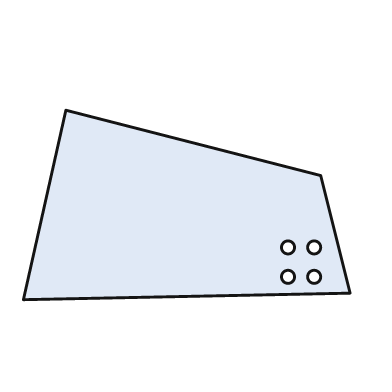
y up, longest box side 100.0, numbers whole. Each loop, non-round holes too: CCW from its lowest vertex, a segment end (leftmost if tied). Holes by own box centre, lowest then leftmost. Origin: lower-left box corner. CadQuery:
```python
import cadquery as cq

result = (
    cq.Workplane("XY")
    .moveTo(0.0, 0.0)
    .lineTo(100.0, 2.0)
    .lineTo(91.0, 38.0)
    .lineTo(13.0, 58.0)
    .close()
    .moveTo(81.0, 7.0)
    .circle(2.0)
    .moveTo(89.0, 7.0)
    .circle(2.0)
    .moveTo(81.0, 16.0)
    .circle(2.0)
    .moveTo(89.0, 16.0)
    .circle(2.0)
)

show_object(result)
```